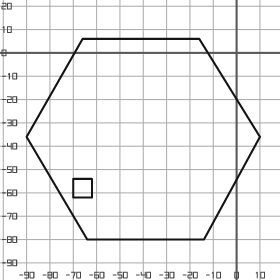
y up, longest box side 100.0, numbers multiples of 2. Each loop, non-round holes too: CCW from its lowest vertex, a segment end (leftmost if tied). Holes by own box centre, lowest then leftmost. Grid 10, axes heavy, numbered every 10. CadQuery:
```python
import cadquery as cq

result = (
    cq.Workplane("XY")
    .moveTo(-64.0, -80.0)
    .lineTo(-14.0, -80.0)
    .lineTo(10.0, -36.0)
    .lineTo(-16.0, 6.0)
    .lineTo(-66.0, 6.0)
    .lineTo(-90.0, -36.0)
    .close()
    .moveTo(-70.0, -62.0)
    .lineTo(-62.0, -62.0)
    .lineTo(-62.0, -54.0)
    .lineTo(-70.0, -54.0)
    .close()
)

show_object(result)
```